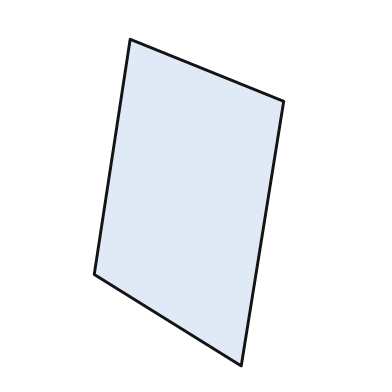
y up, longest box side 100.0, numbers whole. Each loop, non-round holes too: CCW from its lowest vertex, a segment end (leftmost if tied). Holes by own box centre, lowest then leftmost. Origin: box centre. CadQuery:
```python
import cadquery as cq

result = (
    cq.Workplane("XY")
    .moveTo(16.0, -50.0)
    .lineTo(29.0, 31.0)
    .lineTo(-18.0, 50.0)
    .lineTo(-29.0, -22.0)
    .close()
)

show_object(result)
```